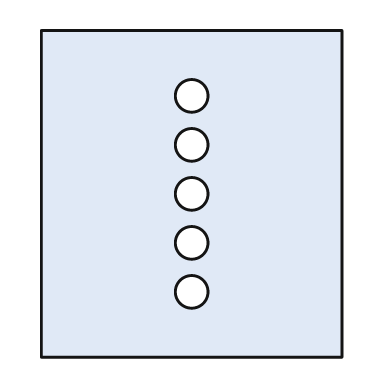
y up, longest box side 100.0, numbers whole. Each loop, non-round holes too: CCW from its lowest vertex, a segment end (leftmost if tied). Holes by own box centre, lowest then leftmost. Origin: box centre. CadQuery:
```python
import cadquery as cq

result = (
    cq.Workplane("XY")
    .moveTo(-46.0, -50.0)
    .lineTo(46.0, -50.0)
    .lineTo(46.0, 50.0)
    .lineTo(-46.0, 50.0)
    .close()
    .moveTo(0.0, -30.0)
    .circle(5.0)
    .moveTo(0.0, -15.0)
    .circle(5.0)
    .moveTo(0.0, 0.0)
    .circle(5.0)
    .moveTo(0.0, 15.0)
    .circle(5.0)
    .moveTo(0.0, 30.0)
    .circle(5.0)
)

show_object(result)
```